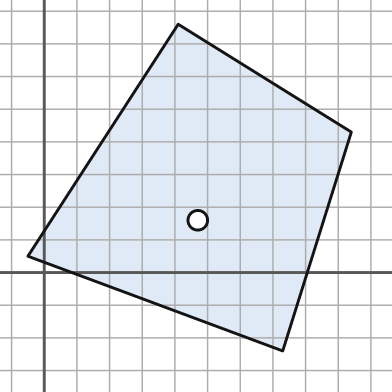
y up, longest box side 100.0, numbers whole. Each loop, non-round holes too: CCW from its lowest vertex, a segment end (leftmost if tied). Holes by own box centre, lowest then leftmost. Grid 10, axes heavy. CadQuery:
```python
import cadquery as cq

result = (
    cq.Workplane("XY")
    .moveTo(73.0, -24.0)
    .lineTo(94.0, 43.0)
    .lineTo(41.0, 76.0)
    .lineTo(-5.0, 5.0)
    .close()
    .moveTo(47.0, 16.0)
    .circle(3.0)
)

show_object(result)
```